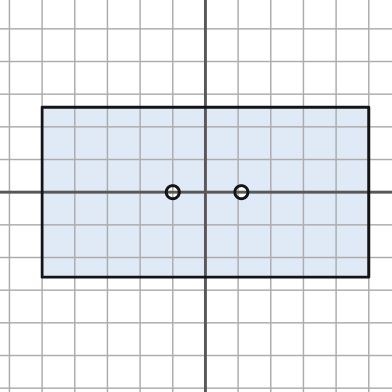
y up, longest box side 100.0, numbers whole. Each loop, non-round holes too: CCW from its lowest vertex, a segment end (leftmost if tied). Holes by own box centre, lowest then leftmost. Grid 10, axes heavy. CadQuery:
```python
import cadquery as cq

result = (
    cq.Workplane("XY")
    .moveTo(-50.0, -26.0)
    .lineTo(50.0, -26.0)
    .lineTo(50.0, 26.0)
    .lineTo(-50.0, 26.0)
    .close()
    .moveTo(-10.0, 0.0)
    .circle(2.0)
    .moveTo(11.0, 0.0)
    .circle(2.0)
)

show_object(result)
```